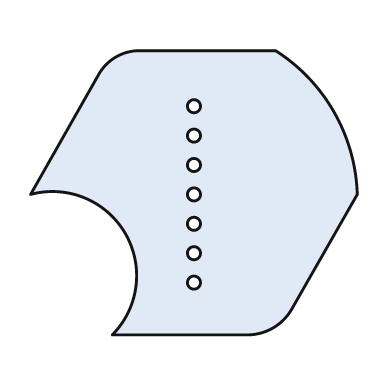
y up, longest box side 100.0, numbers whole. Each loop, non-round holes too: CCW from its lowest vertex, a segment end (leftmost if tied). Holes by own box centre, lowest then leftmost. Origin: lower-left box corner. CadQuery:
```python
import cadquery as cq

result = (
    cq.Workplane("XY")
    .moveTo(25.0, 0.0)
    .lineTo(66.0, 0.0)
    .threePointArc((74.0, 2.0), (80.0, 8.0))
    .lineTo(100.0, 43.0)
    .threePointArc((93.0, 68.0), (75.0, 87.0))
    .lineTo(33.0, 87.0)
    .threePointArc((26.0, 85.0), (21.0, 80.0))
    .lineTo(0.0, 43.0)
    .threePointArc((29.0, 31.0), (25.0, 0.0))
    .close()
    .moveTo(50.0, 16.0)
    .circle(2.0)
    .moveTo(50.0, 25.0)
    .circle(2.0)
    .moveTo(50.0, 34.0)
    .circle(2.0)
    .moveTo(50.0, 43.0)
    .circle(2.0)
    .moveTo(50.0, 52.0)
    .circle(2.0)
    .moveTo(50.0, 61.0)
    .circle(2.0)
    .moveTo(50.0, 70.0)
    .circle(2.0)
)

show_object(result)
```